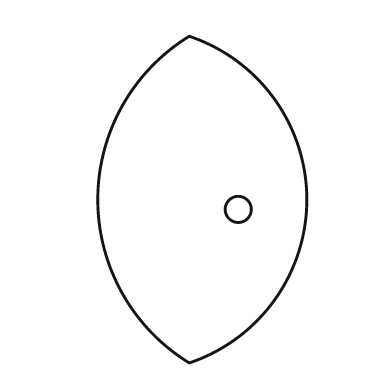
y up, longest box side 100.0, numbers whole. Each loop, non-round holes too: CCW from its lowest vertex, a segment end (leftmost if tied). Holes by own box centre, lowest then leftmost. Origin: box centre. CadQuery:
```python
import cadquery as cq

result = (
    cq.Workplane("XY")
    .moveTo(-4.0, -50.0)
    .threePointArc((32.0, 0.0), (-4.0, 50.0))
    .threePointArc((-32.0, 0.0), (-4.0, -50.0))
    .close()
    .moveTo(11.0, -3.0)
    .circle(4.0)
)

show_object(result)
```